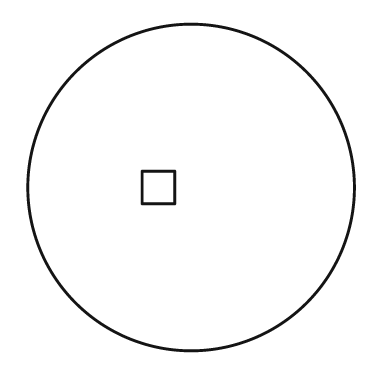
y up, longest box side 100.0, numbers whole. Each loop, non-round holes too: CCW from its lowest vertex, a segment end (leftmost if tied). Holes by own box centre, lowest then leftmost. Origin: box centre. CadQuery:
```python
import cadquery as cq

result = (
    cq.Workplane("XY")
    .moveTo(0.0, 0.0)
    .circle(50.0)
    .moveTo(-15.0, -5.0)
    .lineTo(-5.0, -5.0)
    .lineTo(-5.0, 5.0)
    .lineTo(-15.0, 5.0)
    .close()
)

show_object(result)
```